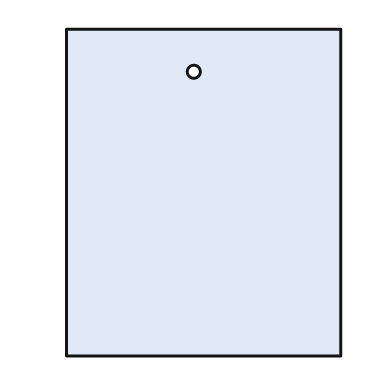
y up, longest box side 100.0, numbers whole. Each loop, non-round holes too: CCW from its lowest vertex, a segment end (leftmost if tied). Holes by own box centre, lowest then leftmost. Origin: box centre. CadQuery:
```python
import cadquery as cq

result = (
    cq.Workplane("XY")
    .moveTo(-42.0, -50.0)
    .lineTo(42.0, -50.0)
    .lineTo(42.0, 50.0)
    .lineTo(-42.0, 50.0)
    .close()
    .moveTo(-3.0, 37.0)
    .circle(2.0)
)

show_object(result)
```